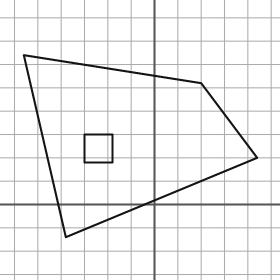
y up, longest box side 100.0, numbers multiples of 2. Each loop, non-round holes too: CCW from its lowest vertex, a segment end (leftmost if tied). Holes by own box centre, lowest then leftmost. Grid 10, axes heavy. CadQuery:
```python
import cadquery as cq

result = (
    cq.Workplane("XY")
    .moveTo(-38.0, -14.0)
    .lineTo(44.0, 20.0)
    .lineTo(20.0, 52.0)
    .lineTo(-56.0, 64.0)
    .close()
    .moveTo(-30.0, 18.0)
    .lineTo(-18.0, 18.0)
    .lineTo(-18.0, 30.0)
    .lineTo(-30.0, 30.0)
    .close()
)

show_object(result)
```